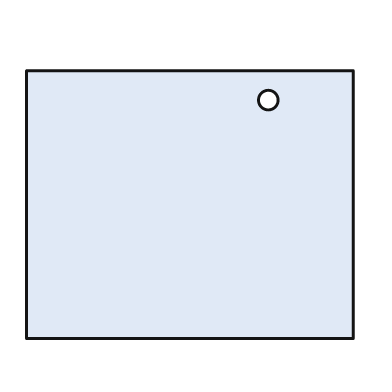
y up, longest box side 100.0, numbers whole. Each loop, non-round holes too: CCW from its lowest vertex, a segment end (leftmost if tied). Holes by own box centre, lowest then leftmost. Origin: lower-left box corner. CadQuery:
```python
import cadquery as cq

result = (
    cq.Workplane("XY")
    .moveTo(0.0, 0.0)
    .lineTo(100.0, 0.0)
    .lineTo(100.0, 82.0)
    .lineTo(0.0, 82.0)
    .close()
    .moveTo(74.0, 73.0)
    .circle(3.0)
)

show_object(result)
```